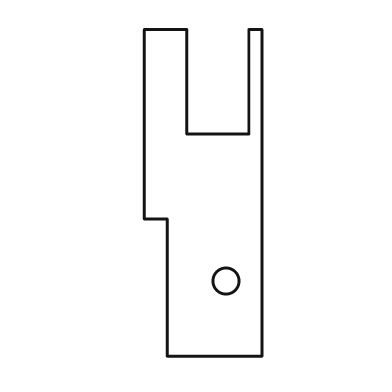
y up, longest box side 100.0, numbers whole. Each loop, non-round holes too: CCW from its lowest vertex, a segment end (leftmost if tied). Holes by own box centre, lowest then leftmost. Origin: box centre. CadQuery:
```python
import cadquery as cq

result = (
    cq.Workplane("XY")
    .moveTo(-11.0, -50.0)
    .lineTo(18.0, -50.0)
    .lineTo(18.0, 50.0)
    .lineTo(14.0, 50.0)
    .lineTo(14.0, 18.0)
    .lineTo(-5.0, 18.0)
    .lineTo(-5.0, 50.0)
    .lineTo(-18.0, 50.0)
    .lineTo(-18.0, -8.0)
    .lineTo(-11.0, -8.0)
    .close()
    .moveTo(7.0, -27.0)
    .circle(4.0)
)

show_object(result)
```